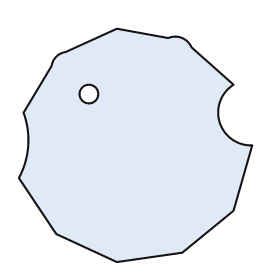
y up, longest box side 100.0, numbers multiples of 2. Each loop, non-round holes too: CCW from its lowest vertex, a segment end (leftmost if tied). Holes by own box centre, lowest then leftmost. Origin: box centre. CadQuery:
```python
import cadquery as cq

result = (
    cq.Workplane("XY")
    .moveTo(-8.0, -50.0)
    .lineTo(20.0, -46.0)
    .lineTo(42.0, -28.0)
    .lineTo(50.0, 0.0)
    .threePointArc((36.0, 10.0), (42.0, 26.0))
    .lineTo(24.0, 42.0)
    .threePointArc((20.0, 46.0), (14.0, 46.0))
    .lineTo(-8.0, 50.0)
    .lineTo(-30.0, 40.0)
    .threePointArc((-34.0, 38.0), (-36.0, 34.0))
    .lineTo(-48.0, 14.0)
    .threePointArc((-46.0, 0.0), (-50.0, -14.0))
    .lineTo(-34.0, -38.0)
    .close()
    .moveTo(-20.0, 22.0)
    .circle(4.0)
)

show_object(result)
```